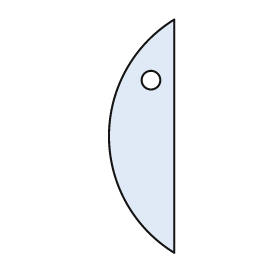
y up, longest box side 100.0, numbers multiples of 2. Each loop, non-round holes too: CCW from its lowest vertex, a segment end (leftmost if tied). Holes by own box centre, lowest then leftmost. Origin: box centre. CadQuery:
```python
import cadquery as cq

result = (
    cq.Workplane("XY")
    .moveTo(14.0, -50.0)
    .lineTo(14.0, 50.0)
    .threePointArc((-14.0, 0.0), (14.0, -50.0))
    .close()
    .moveTo(4.0, 24.0)
    .circle(4.0)
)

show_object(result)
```